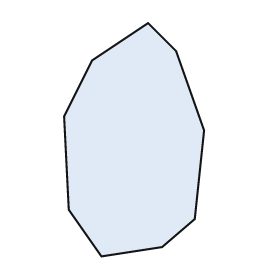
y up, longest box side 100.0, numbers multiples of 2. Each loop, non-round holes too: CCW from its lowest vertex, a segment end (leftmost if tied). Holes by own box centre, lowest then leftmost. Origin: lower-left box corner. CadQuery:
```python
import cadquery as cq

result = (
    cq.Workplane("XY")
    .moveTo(16.0, 0.0)
    .lineTo(42.0, 4.0)
    .lineTo(56.0, 16.0)
    .lineTo(60.0, 54.0)
    .lineTo(48.0, 88.0)
    .lineTo(36.0, 100.0)
    .lineTo(12.0, 84.0)
    .lineTo(0.0, 60.0)
    .lineTo(2.0, 20.0)
    .close()
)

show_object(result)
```